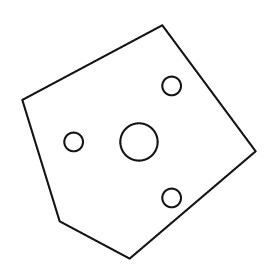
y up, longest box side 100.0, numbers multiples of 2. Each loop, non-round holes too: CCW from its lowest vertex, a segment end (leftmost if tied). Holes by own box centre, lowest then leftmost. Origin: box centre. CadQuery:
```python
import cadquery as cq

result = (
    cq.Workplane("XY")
    .moveTo(-4.0, -50.0)
    .lineTo(50.0, -4.0)
    .lineTo(10.0, 50.0)
    .lineTo(-50.0, 18.0)
    .lineTo(-34.0, -34.0)
    .close()
    .moveTo(14.0, -24.0)
    .circle(4.0)
    .moveTo(-28.0, 0.0)
    .circle(4.0)
    .moveTo(0.0, 0.0)
    .circle(8.0)
    .moveTo(14.0, 24.0)
    .circle(4.0)
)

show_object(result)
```